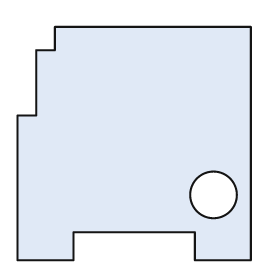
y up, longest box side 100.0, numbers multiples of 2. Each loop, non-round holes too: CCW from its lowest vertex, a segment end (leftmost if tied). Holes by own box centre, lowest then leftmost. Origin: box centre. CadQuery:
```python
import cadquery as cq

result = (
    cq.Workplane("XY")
    .moveTo(-50.0, -50.0)
    .lineTo(-26.0, -50.0)
    .lineTo(-26.0, -38.0)
    .lineTo(26.0, -38.0)
    .lineTo(26.0, -50.0)
    .lineTo(50.0, -50.0)
    .lineTo(50.0, 50.0)
    .lineTo(-34.0, 50.0)
    .lineTo(-34.0, 40.0)
    .lineTo(-42.0, 40.0)
    .lineTo(-42.0, 12.0)
    .lineTo(-50.0, 12.0)
    .close()
    .moveTo(34.0, -22.0)
    .circle(10.0)
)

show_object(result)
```